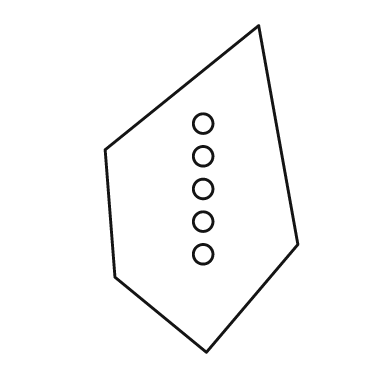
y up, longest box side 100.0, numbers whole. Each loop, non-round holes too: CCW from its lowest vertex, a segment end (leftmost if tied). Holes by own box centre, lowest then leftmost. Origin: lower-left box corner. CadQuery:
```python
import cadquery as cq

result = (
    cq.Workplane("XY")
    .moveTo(31.0, 0.0)
    .lineTo(59.0, 33.0)
    .lineTo(47.0, 100.0)
    .lineTo(0.0, 62.0)
    .lineTo(3.0, 23.0)
    .close()
    .moveTo(30.0, 30.0)
    .circle(3.0)
    .moveTo(30.0, 40.0)
    .circle(3.0)
    .moveTo(30.0, 50.0)
    .circle(3.0)
    .moveTo(30.0, 60.0)
    .circle(3.0)
    .moveTo(30.0, 70.0)
    .circle(3.0)
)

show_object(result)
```